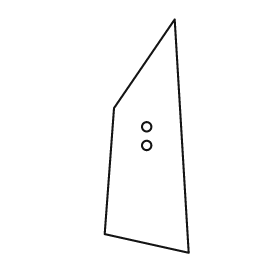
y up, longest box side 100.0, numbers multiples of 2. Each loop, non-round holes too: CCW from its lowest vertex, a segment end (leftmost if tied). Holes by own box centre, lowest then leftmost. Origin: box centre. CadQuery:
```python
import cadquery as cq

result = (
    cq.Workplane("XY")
    .moveTo(18.0, -50.0)
    .lineTo(12.0, 50.0)
    .lineTo(-14.0, 12.0)
    .lineTo(-18.0, -42.0)
    .close()
    .moveTo(0.0, -4.0)
    .circle(2.0)
    .moveTo(0.0, 4.0)
    .circle(2.0)
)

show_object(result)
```